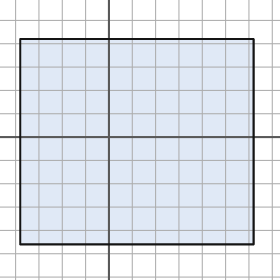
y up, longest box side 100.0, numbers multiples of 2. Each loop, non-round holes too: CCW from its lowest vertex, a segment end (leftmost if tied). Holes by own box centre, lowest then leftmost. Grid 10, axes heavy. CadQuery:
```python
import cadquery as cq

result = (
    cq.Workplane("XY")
    .moveTo(-38.0, -46.0)
    .lineTo(62.0, -46.0)
    .lineTo(62.0, 42.0)
    .lineTo(-38.0, 42.0)
    .close()
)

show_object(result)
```